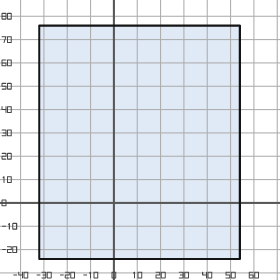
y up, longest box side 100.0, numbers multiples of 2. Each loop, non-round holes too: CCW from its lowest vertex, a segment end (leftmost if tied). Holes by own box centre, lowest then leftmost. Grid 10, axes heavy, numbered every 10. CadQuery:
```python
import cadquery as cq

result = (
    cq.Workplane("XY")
    .moveTo(-32.0, -24.0)
    .lineTo(54.0, -24.0)
    .lineTo(54.0, 76.0)
    .lineTo(-32.0, 76.0)
    .close()
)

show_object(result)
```